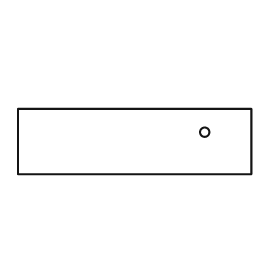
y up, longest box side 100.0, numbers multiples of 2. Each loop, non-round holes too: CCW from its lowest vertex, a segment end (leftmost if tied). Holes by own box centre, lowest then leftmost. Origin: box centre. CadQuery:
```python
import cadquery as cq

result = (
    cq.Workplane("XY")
    .moveTo(-50.0, -14.0)
    .lineTo(50.0, -14.0)
    .lineTo(50.0, 14.0)
    .lineTo(-50.0, 14.0)
    .close()
    .moveTo(30.0, 4.0)
    .circle(2.0)
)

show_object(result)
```